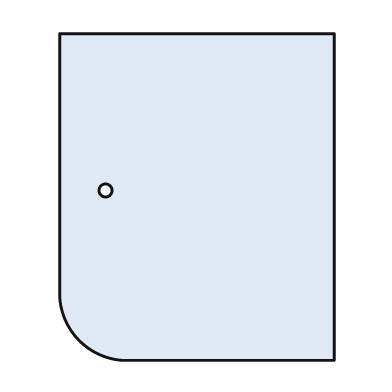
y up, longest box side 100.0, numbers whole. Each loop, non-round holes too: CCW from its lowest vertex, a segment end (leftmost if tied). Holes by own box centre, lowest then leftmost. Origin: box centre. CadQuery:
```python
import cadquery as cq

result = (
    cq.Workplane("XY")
    .moveTo(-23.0, -50.0)
    .lineTo(42.0, -50.0)
    .lineTo(42.0, 50.0)
    .lineTo(-42.0, 50.0)
    .lineTo(-42.0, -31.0)
    .threePointArc((-36.0, -44.0), (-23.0, -50.0))
    .close()
    .moveTo(-28.0, 2.0)
    .circle(2.0)
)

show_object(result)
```